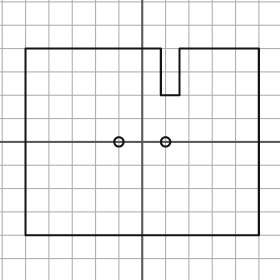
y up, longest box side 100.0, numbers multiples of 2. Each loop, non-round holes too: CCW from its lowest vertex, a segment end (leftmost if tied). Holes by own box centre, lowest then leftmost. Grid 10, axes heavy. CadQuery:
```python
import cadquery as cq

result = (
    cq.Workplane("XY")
    .moveTo(-50.0, -40.0)
    .lineTo(50.0, -40.0)
    .lineTo(50.0, 40.0)
    .lineTo(16.0, 40.0)
    .lineTo(16.0, 20.0)
    .lineTo(8.0, 20.0)
    .lineTo(8.0, 40.0)
    .lineTo(-50.0, 40.0)
    .close()
    .moveTo(-10.0, 0.0)
    .circle(2.0)
    .moveTo(10.0, 0.0)
    .circle(2.0)
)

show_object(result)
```